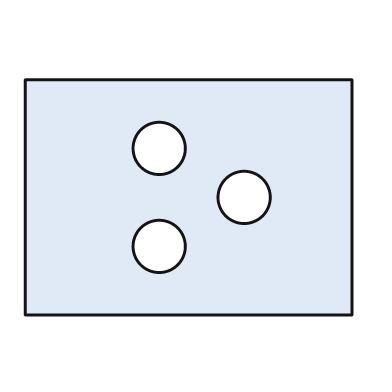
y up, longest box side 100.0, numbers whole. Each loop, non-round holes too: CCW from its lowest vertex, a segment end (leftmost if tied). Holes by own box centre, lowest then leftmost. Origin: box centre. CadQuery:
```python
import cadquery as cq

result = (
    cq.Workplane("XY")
    .moveTo(-50.0, -36.0)
    .lineTo(50.0, -36.0)
    .lineTo(50.0, 36.0)
    .lineTo(-50.0, 36.0)
    .close()
    .moveTo(-9.0, -15.0)
    .circle(8.0)
    .moveTo(17.0, 0.0)
    .circle(8.0)
    .moveTo(-9.0, 15.0)
    .circle(8.0)
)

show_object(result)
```